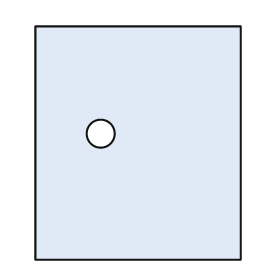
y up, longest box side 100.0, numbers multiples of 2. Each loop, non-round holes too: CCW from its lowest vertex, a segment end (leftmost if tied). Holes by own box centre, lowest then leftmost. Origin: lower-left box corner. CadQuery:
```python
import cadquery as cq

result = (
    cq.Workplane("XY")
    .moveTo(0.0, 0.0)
    .lineTo(88.0, 0.0)
    .lineTo(88.0, 100.0)
    .lineTo(0.0, 100.0)
    .close()
    .moveTo(28.0, 54.0)
    .circle(6.0)
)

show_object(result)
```